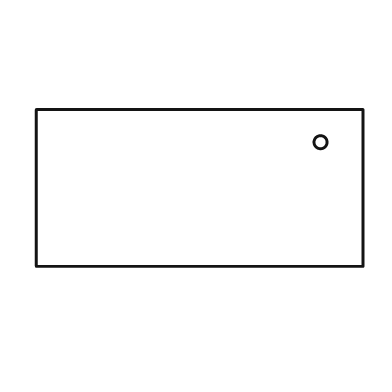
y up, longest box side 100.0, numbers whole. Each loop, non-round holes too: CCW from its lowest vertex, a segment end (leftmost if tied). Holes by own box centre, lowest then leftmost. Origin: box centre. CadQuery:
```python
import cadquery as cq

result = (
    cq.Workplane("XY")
    .moveTo(-50.0, -24.0)
    .lineTo(50.0, -24.0)
    .lineTo(50.0, 24.0)
    .lineTo(-50.0, 24.0)
    .close()
    .moveTo(37.0, 14.0)
    .circle(2.0)
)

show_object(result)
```